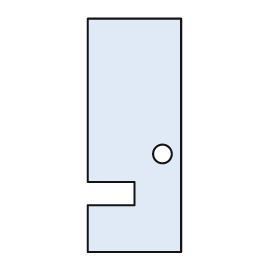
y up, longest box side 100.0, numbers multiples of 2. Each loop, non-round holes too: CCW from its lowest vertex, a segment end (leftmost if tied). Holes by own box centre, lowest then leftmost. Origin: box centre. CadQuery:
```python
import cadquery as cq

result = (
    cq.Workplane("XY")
    .moveTo(-20.0, -50.0)
    .lineTo(20.0, -50.0)
    .lineTo(20.0, 50.0)
    .lineTo(-20.0, 50.0)
    .lineTo(-20.0, -20.0)
    .lineTo(0.0, -20.0)
    .lineTo(0.0, -30.0)
    .lineTo(-20.0, -30.0)
    .close()
    .moveTo(12.0, -8.0)
    .circle(4.0)
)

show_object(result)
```